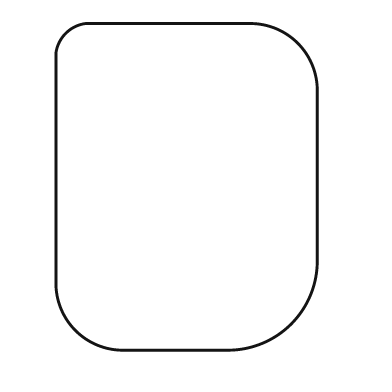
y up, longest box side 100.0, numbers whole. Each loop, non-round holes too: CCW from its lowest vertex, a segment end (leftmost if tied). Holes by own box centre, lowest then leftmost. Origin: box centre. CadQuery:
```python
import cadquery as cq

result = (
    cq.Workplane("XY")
    .moveTo(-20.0, -50.0)
    .lineTo(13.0, -50.0)
    .threePointArc((32.0, -42.0), (40.0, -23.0))
    .lineTo(40.0, 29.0)
    .threePointArc((34.0, 44.0), (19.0, 50.0))
    .lineTo(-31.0, 50.0)
    .threePointArc((-37.0, 47.0), (-40.0, 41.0))
    .lineTo(-40.0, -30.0)
    .threePointArc((-34.0, -44.0), (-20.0, -50.0))
    .close()
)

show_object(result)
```